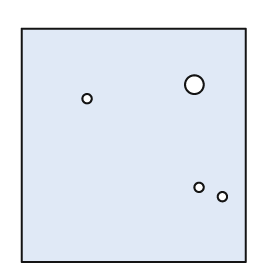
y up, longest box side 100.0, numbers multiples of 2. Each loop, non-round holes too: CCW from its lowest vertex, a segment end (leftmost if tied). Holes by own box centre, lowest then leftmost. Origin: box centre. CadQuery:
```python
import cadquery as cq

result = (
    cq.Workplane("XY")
    .moveTo(-48.0, -50.0)
    .lineTo(48.0, -50.0)
    .lineTo(48.0, 50.0)
    .lineTo(-48.0, 50.0)
    .close()
    .moveTo(38.0, -22.0)
    .circle(2.0)
    .moveTo(28.0, -18.0)
    .circle(2.0)
    .moveTo(-20.0, 20.0)
    .circle(2.0)
    .moveTo(26.0, 26.0)
    .circle(4.0)
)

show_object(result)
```